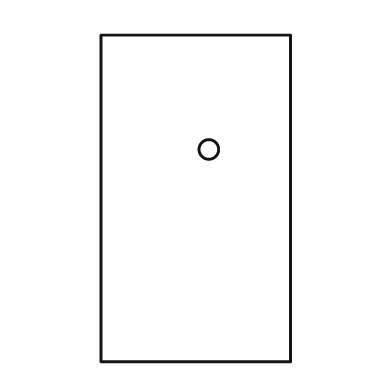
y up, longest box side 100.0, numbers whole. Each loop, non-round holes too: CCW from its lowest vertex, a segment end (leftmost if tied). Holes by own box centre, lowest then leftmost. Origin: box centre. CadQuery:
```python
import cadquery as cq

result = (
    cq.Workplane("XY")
    .moveTo(-29.0, -50.0)
    .lineTo(29.0, -50.0)
    .lineTo(29.0, 50.0)
    .lineTo(-29.0, 50.0)
    .close()
    .moveTo(4.0, 15.0)
    .circle(3.0)
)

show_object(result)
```